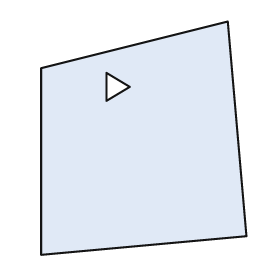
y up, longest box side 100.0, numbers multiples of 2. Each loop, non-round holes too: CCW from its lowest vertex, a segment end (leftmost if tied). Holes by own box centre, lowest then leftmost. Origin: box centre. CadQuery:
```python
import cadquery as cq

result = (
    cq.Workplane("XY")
    .moveTo(-44.0, -50.0)
    .lineTo(44.0, -42.0)
    .lineTo(36.0, 50.0)
    .lineTo(-44.0, 30.0)
    .close()
    .moveTo(-16.0, 16.0)
    .lineTo(-6.0, 22.0)
    .lineTo(-16.0, 28.0)
    .close()
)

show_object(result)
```